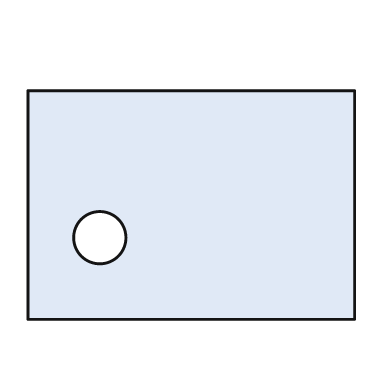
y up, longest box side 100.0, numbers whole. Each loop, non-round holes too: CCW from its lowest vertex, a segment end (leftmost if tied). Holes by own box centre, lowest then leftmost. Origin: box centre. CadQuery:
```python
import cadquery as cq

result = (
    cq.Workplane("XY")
    .moveTo(-50.0, -35.0)
    .lineTo(50.0, -35.0)
    .lineTo(50.0, 35.0)
    .lineTo(-50.0, 35.0)
    .close()
    .moveTo(-28.0, -10.0)
    .circle(8.0)
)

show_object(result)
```